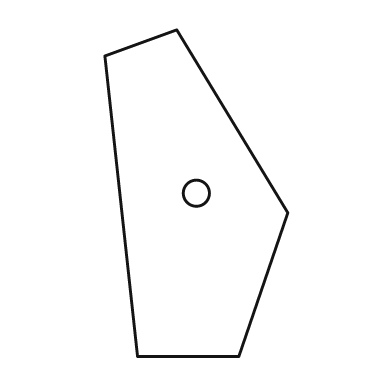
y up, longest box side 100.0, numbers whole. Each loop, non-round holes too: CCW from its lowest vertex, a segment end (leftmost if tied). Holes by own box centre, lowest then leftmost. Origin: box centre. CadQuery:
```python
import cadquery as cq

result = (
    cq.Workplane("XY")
    .moveTo(-18.0, -50.0)
    .lineTo(13.0, -50.0)
    .lineTo(28.0, -6.0)
    .lineTo(-6.0, 50.0)
    .lineTo(-28.0, 42.0)
    .close()
    .moveTo(0.0, 0.0)
    .circle(4.0)
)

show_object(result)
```